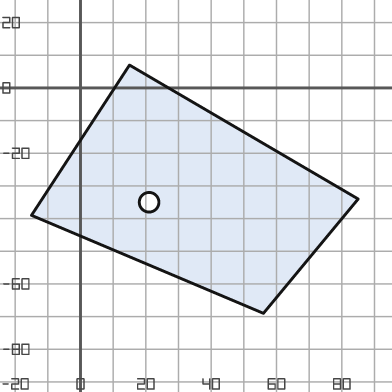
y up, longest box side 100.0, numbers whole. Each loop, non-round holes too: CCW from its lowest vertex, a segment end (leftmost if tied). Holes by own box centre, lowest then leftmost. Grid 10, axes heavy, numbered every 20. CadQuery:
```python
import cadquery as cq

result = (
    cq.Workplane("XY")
    .moveTo(56.0, -69.0)
    .lineTo(85.0, -34.0)
    .lineTo(15.0, 7.0)
    .lineTo(-15.0, -39.0)
    .close()
    .moveTo(21.0, -35.0)
    .circle(3.0)
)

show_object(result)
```